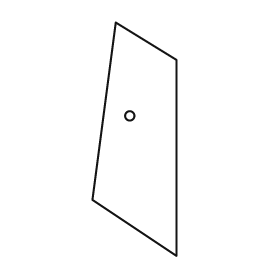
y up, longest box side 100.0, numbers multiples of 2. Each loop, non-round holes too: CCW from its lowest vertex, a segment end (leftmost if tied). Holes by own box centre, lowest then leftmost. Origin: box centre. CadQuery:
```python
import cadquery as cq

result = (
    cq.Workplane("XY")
    .moveTo(18.0, -50.0)
    .lineTo(18.0, 34.0)
    .lineTo(-8.0, 50.0)
    .lineTo(-18.0, -26.0)
    .close()
    .moveTo(-2.0, 10.0)
    .circle(2.0)
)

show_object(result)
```